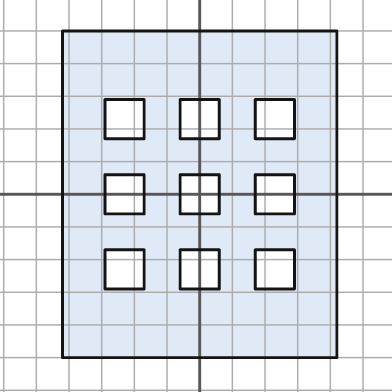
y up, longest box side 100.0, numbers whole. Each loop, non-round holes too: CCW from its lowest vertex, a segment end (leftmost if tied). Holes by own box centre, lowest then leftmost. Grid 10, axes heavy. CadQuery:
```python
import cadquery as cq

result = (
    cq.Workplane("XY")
    .moveTo(-42.0, -50.0)
    .lineTo(42.0, -50.0)
    .lineTo(42.0, 50.0)
    .lineTo(-42.0, 50.0)
    .close()
    .moveTo(-29.0, -29.0)
    .lineTo(-17.0, -29.0)
    .lineTo(-17.0, -17.0)
    .lineTo(-29.0, -17.0)
    .close()
    .moveTo(-6.0, -29.0)
    .lineTo(6.0, -29.0)
    .lineTo(6.0, -17.0)
    .lineTo(-6.0, -17.0)
    .close()
    .moveTo(17.0, -29.0)
    .lineTo(29.0, -29.0)
    .lineTo(29.0, -17.0)
    .lineTo(17.0, -17.0)
    .close()
    .moveTo(-29.0, -6.0)
    .lineTo(-17.0, -6.0)
    .lineTo(-17.0, 6.0)
    .lineTo(-29.0, 6.0)
    .close()
    .moveTo(-6.0, -6.0)
    .lineTo(6.0, -6.0)
    .lineTo(6.0, 6.0)
    .lineTo(-6.0, 6.0)
    .close()
    .moveTo(17.0, -6.0)
    .lineTo(29.0, -6.0)
    .lineTo(29.0, 6.0)
    .lineTo(17.0, 6.0)
    .close()
    .moveTo(-29.0, 17.0)
    .lineTo(-17.0, 17.0)
    .lineTo(-17.0, 29.0)
    .lineTo(-29.0, 29.0)
    .close()
    .moveTo(-6.0, 17.0)
    .lineTo(6.0, 17.0)
    .lineTo(6.0, 29.0)
    .lineTo(-6.0, 29.0)
    .close()
    .moveTo(17.0, 17.0)
    .lineTo(29.0, 17.0)
    .lineTo(29.0, 29.0)
    .lineTo(17.0, 29.0)
    .close()
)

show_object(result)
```